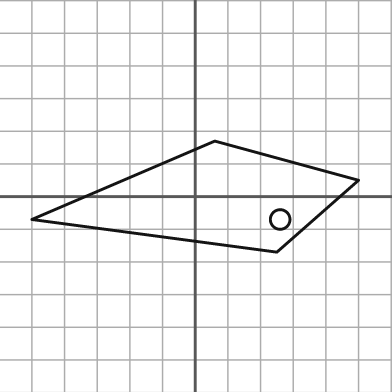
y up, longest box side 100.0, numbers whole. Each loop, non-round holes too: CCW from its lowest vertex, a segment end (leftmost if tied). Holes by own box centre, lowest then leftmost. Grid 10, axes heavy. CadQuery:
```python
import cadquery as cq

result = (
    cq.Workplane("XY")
    .moveTo(25.0, -17.0)
    .lineTo(50.0, 5.0)
    .lineTo(6.0, 17.0)
    .lineTo(-50.0, -7.0)
    .close()
    .moveTo(26.0, -7.0)
    .circle(3.0)
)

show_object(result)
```